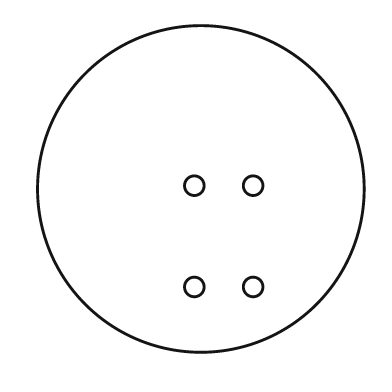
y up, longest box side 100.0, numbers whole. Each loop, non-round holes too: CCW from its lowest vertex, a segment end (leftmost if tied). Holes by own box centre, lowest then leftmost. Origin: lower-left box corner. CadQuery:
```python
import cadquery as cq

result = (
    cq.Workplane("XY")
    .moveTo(50.0, 50.0)
    .circle(50.0)
    .moveTo(48.0, 20.0)
    .circle(3.0)
    .moveTo(66.0, 20.0)
    .circle(3.0)
    .moveTo(48.0, 51.0)
    .circle(3.0)
    .moveTo(66.0, 51.0)
    .circle(3.0)
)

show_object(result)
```